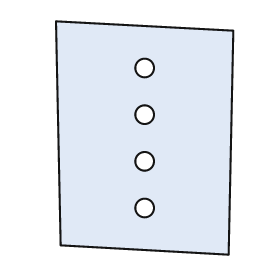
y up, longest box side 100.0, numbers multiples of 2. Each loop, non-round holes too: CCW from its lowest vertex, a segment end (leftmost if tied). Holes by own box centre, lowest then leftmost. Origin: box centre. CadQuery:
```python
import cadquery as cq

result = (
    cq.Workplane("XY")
    .moveTo(36.0, -50.0)
    .lineTo(38.0, 46.0)
    .lineTo(-38.0, 50.0)
    .lineTo(-36.0, -46.0)
    .close()
    .moveTo(0.0, -30.0)
    .circle(4.0)
    .moveTo(0.0, -10.0)
    .circle(4.0)
    .moveTo(0.0, 10.0)
    .circle(4.0)
    .moveTo(0.0, 30.0)
    .circle(4.0)
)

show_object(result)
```